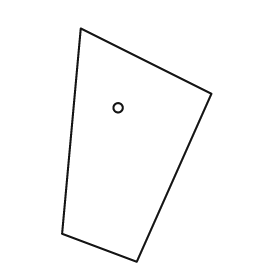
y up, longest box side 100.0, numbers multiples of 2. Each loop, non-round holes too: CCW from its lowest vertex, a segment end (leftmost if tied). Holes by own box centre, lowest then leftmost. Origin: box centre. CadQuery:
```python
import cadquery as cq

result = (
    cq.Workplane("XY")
    .moveTo(0.0, -50.0)
    .lineTo(32.0, 22.0)
    .lineTo(-24.0, 50.0)
    .lineTo(-32.0, -38.0)
    .close()
    .moveTo(-8.0, 16.0)
    .circle(2.0)
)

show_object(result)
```